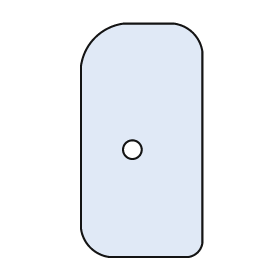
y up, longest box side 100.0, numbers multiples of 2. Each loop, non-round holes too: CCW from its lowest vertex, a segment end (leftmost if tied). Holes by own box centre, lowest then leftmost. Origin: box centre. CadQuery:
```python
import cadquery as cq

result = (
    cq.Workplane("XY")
    .moveTo(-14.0, -50.0)
    .lineTo(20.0, -50.0)
    .threePointArc((24.0, -48.0), (26.0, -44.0))
    .lineTo(26.0, 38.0)
    .threePointArc((22.0, 46.0), (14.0, 50.0))
    .lineTo(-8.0, 50.0)
    .threePointArc((-20.0, 44.0), (-26.0, 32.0))
    .lineTo(-26.0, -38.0)
    .threePointArc((-22.0, -46.0), (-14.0, -50.0))
    .close()
    .moveTo(-4.0, -4.0)
    .circle(4.0)
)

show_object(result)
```